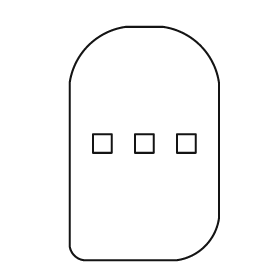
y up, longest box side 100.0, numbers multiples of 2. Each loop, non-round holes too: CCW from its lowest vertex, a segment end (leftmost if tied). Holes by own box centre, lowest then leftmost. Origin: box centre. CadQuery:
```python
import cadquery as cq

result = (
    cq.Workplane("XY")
    .moveTo(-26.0, -50.0)
    .lineTo(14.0, -50.0)
    .threePointArc((26.0, -44.0), (32.0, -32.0))
    .lineTo(32.0, 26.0)
    .threePointArc((24.0, 42.0), (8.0, 50.0))
    .lineTo(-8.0, 50.0)
    .threePointArc((-24.0, 42.0), (-32.0, 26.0))
    .lineTo(-32.0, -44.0)
    .threePointArc((-30.0, -48.0), (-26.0, -50.0))
    .close()
    .moveTo(-22.0, -4.0)
    .lineTo(-14.0, -4.0)
    .lineTo(-14.0, 4.0)
    .lineTo(-22.0, 4.0)
    .close()
    .moveTo(-4.0, -4.0)
    .lineTo(4.0, -4.0)
    .lineTo(4.0, 4.0)
    .lineTo(-4.0, 4.0)
    .close()
    .moveTo(14.0, -4.0)
    .lineTo(22.0, -4.0)
    .lineTo(22.0, 4.0)
    .lineTo(14.0, 4.0)
    .close()
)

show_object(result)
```